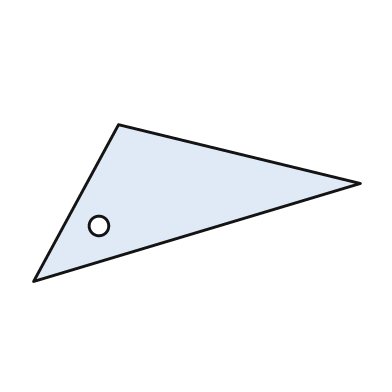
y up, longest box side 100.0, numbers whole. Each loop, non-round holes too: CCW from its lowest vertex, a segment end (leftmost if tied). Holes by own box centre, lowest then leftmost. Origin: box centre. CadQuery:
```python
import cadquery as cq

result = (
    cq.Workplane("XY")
    .moveTo(-50.0, -24.0)
    .lineTo(50.0, 6.0)
    .lineTo(-24.0, 24.0)
    .close()
    .moveTo(-30.0, -7.0)
    .circle(3.0)
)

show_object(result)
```